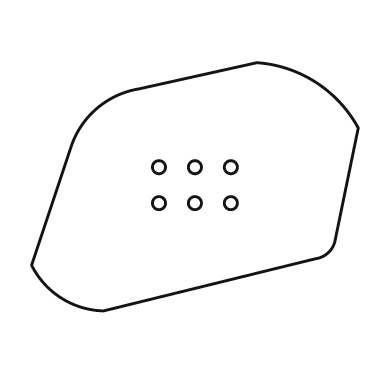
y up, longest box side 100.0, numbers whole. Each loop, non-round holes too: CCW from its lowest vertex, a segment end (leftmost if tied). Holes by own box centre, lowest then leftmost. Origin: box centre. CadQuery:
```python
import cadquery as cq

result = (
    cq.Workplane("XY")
    .moveTo(-28.0, -38.0)
    .lineTo(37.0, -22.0)
    .threePointArc((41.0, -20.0), (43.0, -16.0))
    .lineTo(50.0, 18.0)
    .threePointArc((37.0, 32.0), (19.0, 38.0))
    .lineTo(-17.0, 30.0)
    .threePointArc((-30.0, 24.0), (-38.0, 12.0))
    .lineTo(-50.0, -24.0)
    .threePointArc((-41.0, -34.0), (-28.0, -38.0))
    .close()
    .moveTo(-11.0, -5.0)
    .circle(2.0)
    .moveTo(0.0, -5.0)
    .circle(2.0)
    .moveTo(11.0, -5.0)
    .circle(2.0)
    .moveTo(-11.0, 6.0)
    .circle(2.0)
    .moveTo(0.0, 6.0)
    .circle(2.0)
    .moveTo(11.0, 6.0)
    .circle(2.0)
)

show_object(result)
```